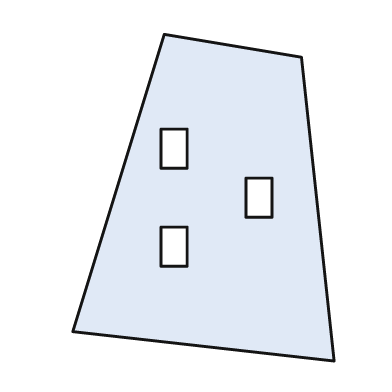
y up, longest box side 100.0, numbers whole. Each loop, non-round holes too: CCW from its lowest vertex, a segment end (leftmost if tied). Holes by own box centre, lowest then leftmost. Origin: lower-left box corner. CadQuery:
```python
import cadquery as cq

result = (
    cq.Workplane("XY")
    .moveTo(80.0, 0.0)
    .lineTo(70.0, 93.0)
    .lineTo(28.0, 100.0)
    .lineTo(0.0, 9.0)
    .close()
    .moveTo(27.0, 29.0)
    .lineTo(35.0, 29.0)
    .lineTo(35.0, 41.0)
    .lineTo(27.0, 41.0)
    .close()
    .moveTo(53.0, 44.0)
    .lineTo(61.0, 44.0)
    .lineTo(61.0, 56.0)
    .lineTo(53.0, 56.0)
    .close()
    .moveTo(27.0, 59.0)
    .lineTo(35.0, 59.0)
    .lineTo(35.0, 71.0)
    .lineTo(27.0, 71.0)
    .close()
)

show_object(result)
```